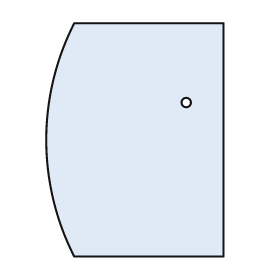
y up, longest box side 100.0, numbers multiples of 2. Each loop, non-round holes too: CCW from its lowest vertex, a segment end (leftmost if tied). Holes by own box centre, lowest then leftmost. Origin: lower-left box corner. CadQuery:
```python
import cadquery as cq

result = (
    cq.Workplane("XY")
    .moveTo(12.0, 0.0)
    .lineTo(76.0, 0.0)
    .lineTo(76.0, 100.0)
    .lineTo(12.0, 100.0)
    .threePointArc((0.0, 50.0), (12.0, 0.0))
    .close()
    .moveTo(60.0, 66.0)
    .circle(2.0)
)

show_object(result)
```